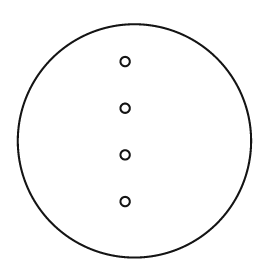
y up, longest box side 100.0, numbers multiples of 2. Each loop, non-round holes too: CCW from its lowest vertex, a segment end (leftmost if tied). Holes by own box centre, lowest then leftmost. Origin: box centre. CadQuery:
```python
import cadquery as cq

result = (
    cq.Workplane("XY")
    .moveTo(0.0, 0.0)
    .circle(50.0)
    .moveTo(-4.0, -26.0)
    .circle(2.0)
    .moveTo(-4.0, -6.0)
    .circle(2.0)
    .moveTo(-4.0, 14.0)
    .circle(2.0)
    .moveTo(-4.0, 34.0)
    .circle(2.0)
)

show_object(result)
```